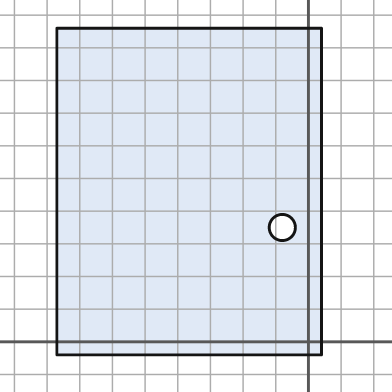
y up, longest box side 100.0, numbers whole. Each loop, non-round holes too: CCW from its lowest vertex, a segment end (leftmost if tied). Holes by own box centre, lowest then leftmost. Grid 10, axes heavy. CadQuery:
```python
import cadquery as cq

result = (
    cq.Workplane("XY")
    .moveTo(-77.0, -4.0)
    .lineTo(4.0, -4.0)
    .lineTo(4.0, 96.0)
    .lineTo(-77.0, 96.0)
    .close()
    .moveTo(-8.0, 35.0)
    .circle(4.0)
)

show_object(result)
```